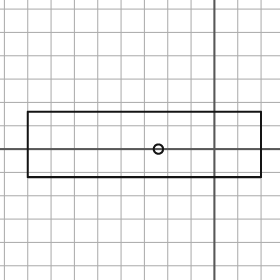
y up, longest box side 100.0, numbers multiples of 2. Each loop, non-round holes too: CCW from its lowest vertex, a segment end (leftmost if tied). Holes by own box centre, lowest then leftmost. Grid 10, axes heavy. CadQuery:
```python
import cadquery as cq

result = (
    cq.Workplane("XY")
    .moveTo(-80.0, -12.0)
    .lineTo(20.0, -12.0)
    .lineTo(20.0, 16.0)
    .lineTo(-80.0, 16.0)
    .close()
    .moveTo(-24.0, 0.0)
    .circle(2.0)
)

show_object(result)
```